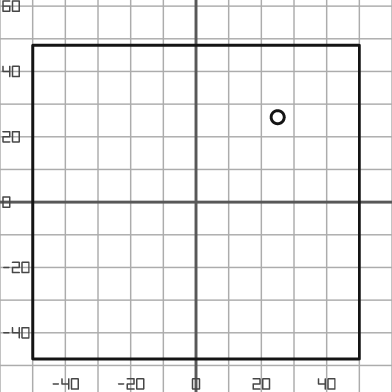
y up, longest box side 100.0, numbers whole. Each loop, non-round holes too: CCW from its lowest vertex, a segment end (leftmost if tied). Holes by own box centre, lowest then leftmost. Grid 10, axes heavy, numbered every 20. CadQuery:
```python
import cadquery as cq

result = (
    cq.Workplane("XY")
    .moveTo(-50.0, -48.0)
    .lineTo(50.0, -48.0)
    .lineTo(50.0, 48.0)
    .lineTo(-50.0, 48.0)
    .close()
    .moveTo(25.0, 26.0)
    .circle(2.0)
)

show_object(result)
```